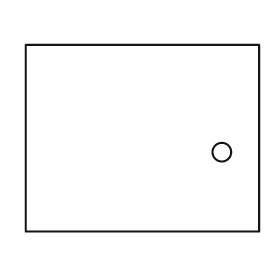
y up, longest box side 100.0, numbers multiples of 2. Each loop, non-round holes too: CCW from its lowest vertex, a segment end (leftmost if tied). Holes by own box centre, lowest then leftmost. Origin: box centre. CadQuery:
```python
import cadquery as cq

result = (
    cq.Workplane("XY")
    .moveTo(-50.0, -40.0)
    .lineTo(50.0, -40.0)
    .lineTo(50.0, 40.0)
    .lineTo(-50.0, 40.0)
    .close()
    .moveTo(34.0, -6.0)
    .circle(4.0)
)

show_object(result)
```